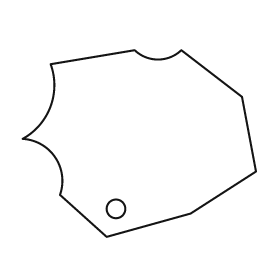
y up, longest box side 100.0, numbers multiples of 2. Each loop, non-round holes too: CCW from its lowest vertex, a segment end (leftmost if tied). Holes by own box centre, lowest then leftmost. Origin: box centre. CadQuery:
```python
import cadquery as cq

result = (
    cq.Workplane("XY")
    .moveTo(-14.0, -40.0)
    .lineTo(22.0, -30.0)
    .lineTo(50.0, -12.0)
    .lineTo(44.0, 20.0)
    .lineTo(18.0, 40.0)
    .threePointArc((8.0, 36.0), (-2.0, 40.0))
    .lineTo(-38.0, 34.0)
    .threePointArc((-38.0, 16.0), (-50.0, 2.0))
    .threePointArc((-36.0, -6.0), (-34.0, -22.0))
    .close()
    .moveTo(-10.0, -28.0)
    .circle(4.0)
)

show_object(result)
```